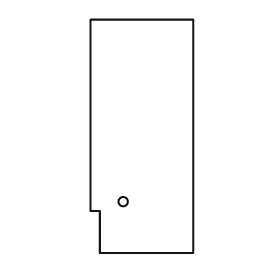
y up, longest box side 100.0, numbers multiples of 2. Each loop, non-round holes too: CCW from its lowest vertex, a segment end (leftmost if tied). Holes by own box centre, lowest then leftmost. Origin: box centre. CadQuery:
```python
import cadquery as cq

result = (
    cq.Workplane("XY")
    .moveTo(-18.0, -50.0)
    .lineTo(22.0, -50.0)
    .lineTo(22.0, 50.0)
    .lineTo(-22.0, 50.0)
    .lineTo(-22.0, -32.0)
    .lineTo(-18.0, -32.0)
    .close()
    .moveTo(-8.0, -28.0)
    .circle(2.0)
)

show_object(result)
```